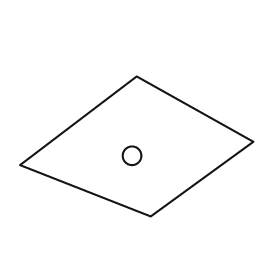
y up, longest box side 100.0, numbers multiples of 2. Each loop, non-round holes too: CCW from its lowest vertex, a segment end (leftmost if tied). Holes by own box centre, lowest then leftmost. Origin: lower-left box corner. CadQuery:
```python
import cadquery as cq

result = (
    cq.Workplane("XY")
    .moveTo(56.0, 0.0)
    .lineTo(100.0, 32.0)
    .lineTo(50.0, 60.0)
    .lineTo(0.0, 22.0)
    .close()
    .moveTo(48.0, 26.0)
    .circle(4.0)
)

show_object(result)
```